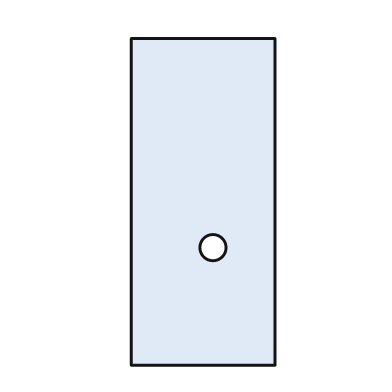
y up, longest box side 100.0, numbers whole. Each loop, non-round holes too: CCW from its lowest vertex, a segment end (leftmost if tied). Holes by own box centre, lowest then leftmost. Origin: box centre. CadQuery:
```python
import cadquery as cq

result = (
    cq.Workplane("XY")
    .moveTo(-22.0, -50.0)
    .lineTo(22.0, -50.0)
    .lineTo(22.0, 50.0)
    .lineTo(-22.0, 50.0)
    .close()
    .moveTo(3.0, -14.0)
    .circle(4.0)
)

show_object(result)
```